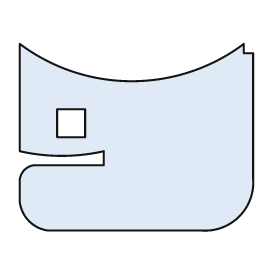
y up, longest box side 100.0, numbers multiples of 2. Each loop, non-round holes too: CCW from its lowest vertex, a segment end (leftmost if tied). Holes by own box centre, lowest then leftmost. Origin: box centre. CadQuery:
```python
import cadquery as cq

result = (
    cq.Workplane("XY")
    .moveTo(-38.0, -40.0)
    .lineTo(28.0, -40.0)
    .threePointArc((44.0, -34.0), (50.0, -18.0))
    .lineTo(50.0, 36.0)
    .lineTo(46.0, 36.0)
    .lineTo(46.0, 40.0)
    .threePointArc((-2.0, 24.0), (-50.0, 40.0))
    .lineTo(-50.0, -6.0)
    .threePointArc((-32.0, -8.0), (-14.0, -6.0))
    .lineTo(-14.0, -12.0)
    .lineTo(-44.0, -12.0)
    .threePointArc((-48.0, -14.0), (-50.0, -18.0))
    .lineTo(-50.0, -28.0)
    .threePointArc((-46.0, -36.0), (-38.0, -40.0))
    .close()
    .moveTo(-34.0, 0.0)
    .lineTo(-22.0, 0.0)
    .lineTo(-22.0, 12.0)
    .lineTo(-34.0, 12.0)
    .close()
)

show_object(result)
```